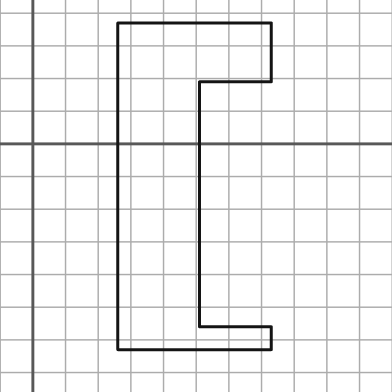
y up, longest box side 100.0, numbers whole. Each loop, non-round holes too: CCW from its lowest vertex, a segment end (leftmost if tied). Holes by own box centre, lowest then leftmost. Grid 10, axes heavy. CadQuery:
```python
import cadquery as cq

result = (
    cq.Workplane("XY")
    .moveTo(26.0, -63.0)
    .lineTo(73.0, -63.0)
    .lineTo(73.0, -56.0)
    .lineTo(51.0, -56.0)
    .lineTo(51.0, 19.0)
    .lineTo(73.0, 19.0)
    .lineTo(73.0, 37.0)
    .lineTo(26.0, 37.0)
    .close()
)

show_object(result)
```